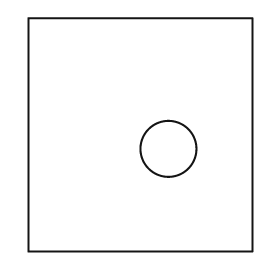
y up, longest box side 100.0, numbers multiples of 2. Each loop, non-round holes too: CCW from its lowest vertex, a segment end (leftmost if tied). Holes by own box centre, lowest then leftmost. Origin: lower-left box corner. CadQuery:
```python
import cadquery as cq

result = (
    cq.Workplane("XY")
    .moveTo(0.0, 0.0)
    .lineTo(96.0, 0.0)
    .lineTo(96.0, 100.0)
    .lineTo(0.0, 100.0)
    .close()
    .moveTo(60.0, 44.0)
    .circle(12.0)
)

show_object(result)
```